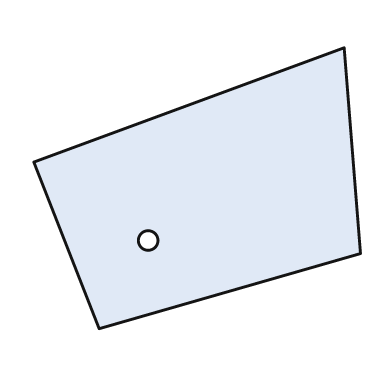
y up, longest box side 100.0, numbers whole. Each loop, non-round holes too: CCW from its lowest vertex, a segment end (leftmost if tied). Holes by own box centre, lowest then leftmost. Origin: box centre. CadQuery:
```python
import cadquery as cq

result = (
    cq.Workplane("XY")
    .moveTo(-30.0, -43.0)
    .lineTo(50.0, -20.0)
    .lineTo(45.0, 43.0)
    .lineTo(-50.0, 8.0)
    .close()
    .moveTo(-15.0, -16.0)
    .circle(3.0)
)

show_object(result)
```